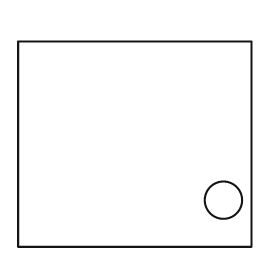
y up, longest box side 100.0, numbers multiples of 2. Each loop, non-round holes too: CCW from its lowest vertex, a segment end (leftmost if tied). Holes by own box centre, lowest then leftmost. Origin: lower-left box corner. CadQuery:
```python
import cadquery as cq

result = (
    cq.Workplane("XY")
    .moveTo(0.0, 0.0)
    .lineTo(100.0, 0.0)
    .lineTo(100.0, 88.0)
    .lineTo(0.0, 88.0)
    .close()
    .moveTo(88.0, 20.0)
    .circle(8.0)
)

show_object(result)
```